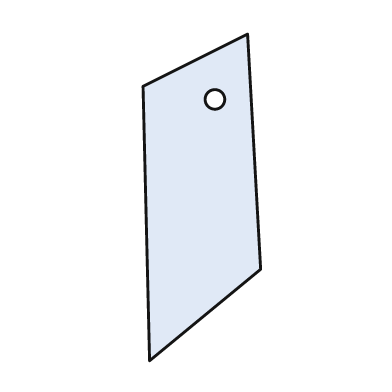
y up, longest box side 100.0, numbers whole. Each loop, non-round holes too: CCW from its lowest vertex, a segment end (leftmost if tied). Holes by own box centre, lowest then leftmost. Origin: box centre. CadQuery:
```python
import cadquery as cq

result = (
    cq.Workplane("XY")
    .moveTo(-16.0, -50.0)
    .lineTo(18.0, -22.0)
    .lineTo(14.0, 50.0)
    .lineTo(-18.0, 34.0)
    .close()
    .moveTo(4.0, 30.0)
    .circle(3.0)
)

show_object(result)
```